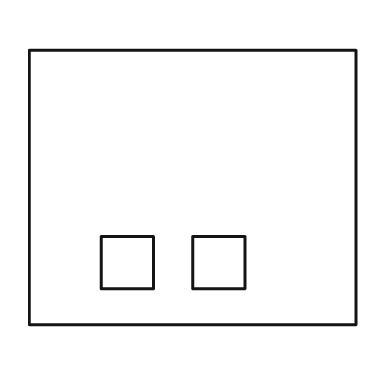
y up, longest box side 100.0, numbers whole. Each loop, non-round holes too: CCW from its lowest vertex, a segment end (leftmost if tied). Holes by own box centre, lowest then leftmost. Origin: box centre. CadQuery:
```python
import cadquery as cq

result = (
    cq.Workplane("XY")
    .moveTo(-50.0, -42.0)
    .lineTo(50.0, -42.0)
    .lineTo(50.0, 42.0)
    .lineTo(-50.0, 42.0)
    .close()
    .moveTo(-28.0, -31.0)
    .lineTo(-12.0, -31.0)
    .lineTo(-12.0, -15.0)
    .lineTo(-28.0, -15.0)
    .close()
    .moveTo(0.0, -31.0)
    .lineTo(16.0, -31.0)
    .lineTo(16.0, -15.0)
    .lineTo(0.0, -15.0)
    .close()
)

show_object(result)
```